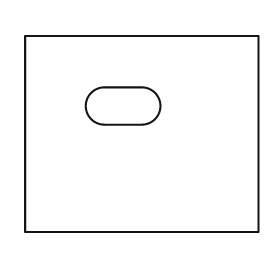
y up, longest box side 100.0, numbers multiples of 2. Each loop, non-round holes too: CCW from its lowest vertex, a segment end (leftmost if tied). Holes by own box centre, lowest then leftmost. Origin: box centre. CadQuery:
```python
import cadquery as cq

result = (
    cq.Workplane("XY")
    .moveTo(-50.0, -42.0)
    .lineTo(50.0, -42.0)
    .lineTo(50.0, 42.0)
    .lineTo(-50.0, 42.0)
    .close()
    .moveTo(-16.0, 4.0)
    .lineTo(0.0, 4.0)
    .threePointArc((8.0, 12.0), (0.0, 20.0))
    .lineTo(-16.0, 20.0)
    .threePointArc((-24.0, 12.0), (-16.0, 4.0))
    .close()
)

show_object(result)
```